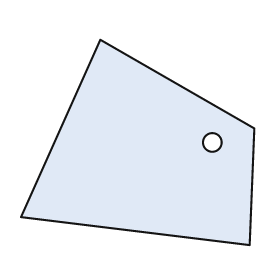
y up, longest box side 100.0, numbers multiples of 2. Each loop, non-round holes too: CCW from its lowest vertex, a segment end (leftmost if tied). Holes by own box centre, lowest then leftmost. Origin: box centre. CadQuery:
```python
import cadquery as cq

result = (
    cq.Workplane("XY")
    .moveTo(48.0, -44.0)
    .lineTo(50.0, 6.0)
    .lineTo(-16.0, 44.0)
    .lineTo(-50.0, -32.0)
    .close()
    .moveTo(32.0, 0.0)
    .circle(4.0)
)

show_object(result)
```